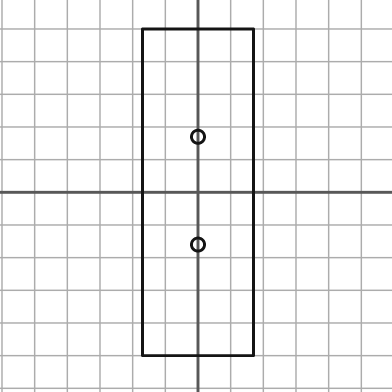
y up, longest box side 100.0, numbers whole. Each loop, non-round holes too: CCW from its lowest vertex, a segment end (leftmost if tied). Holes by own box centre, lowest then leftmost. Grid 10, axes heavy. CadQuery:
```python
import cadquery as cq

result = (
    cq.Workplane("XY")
    .moveTo(-17.0, -50.0)
    .lineTo(17.0, -50.0)
    .lineTo(17.0, 50.0)
    .lineTo(-17.0, 50.0)
    .close()
    .moveTo(0.0, -16.0)
    .circle(2.0)
    .moveTo(0.0, 17.0)
    .circle(2.0)
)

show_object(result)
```